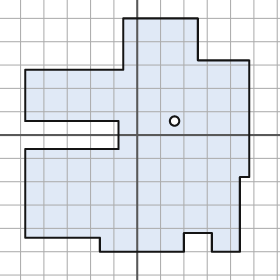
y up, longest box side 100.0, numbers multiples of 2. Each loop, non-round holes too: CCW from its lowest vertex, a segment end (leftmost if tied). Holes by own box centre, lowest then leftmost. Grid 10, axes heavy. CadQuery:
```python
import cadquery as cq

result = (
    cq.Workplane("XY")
    .moveTo(-16.0, -50.0)
    .lineTo(20.0, -50.0)
    .lineTo(20.0, -42.0)
    .lineTo(32.0, -42.0)
    .lineTo(32.0, -50.0)
    .lineTo(44.0, -50.0)
    .lineTo(44.0, -18.0)
    .lineTo(48.0, -18.0)
    .lineTo(48.0, 32.0)
    .lineTo(26.0, 32.0)
    .lineTo(26.0, 50.0)
    .lineTo(-6.0, 50.0)
    .lineTo(-6.0, 28.0)
    .lineTo(-48.0, 28.0)
    .lineTo(-48.0, 6.0)
    .lineTo(-8.0, 6.0)
    .lineTo(-8.0, -6.0)
    .lineTo(-48.0, -6.0)
    .lineTo(-48.0, -44.0)
    .lineTo(-16.0, -44.0)
    .close()
    .moveTo(16.0, 6.0)
    .circle(2.0)
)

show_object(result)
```